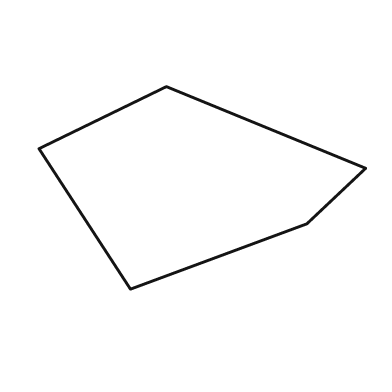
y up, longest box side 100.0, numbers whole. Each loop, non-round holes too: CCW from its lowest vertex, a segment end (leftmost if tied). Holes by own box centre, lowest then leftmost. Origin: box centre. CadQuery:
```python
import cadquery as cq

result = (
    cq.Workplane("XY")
    .moveTo(-22.0, -31.0)
    .lineTo(32.0, -11.0)
    .lineTo(50.0, 6.0)
    .lineTo(-11.0, 31.0)
    .lineTo(-50.0, 12.0)
    .close()
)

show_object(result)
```